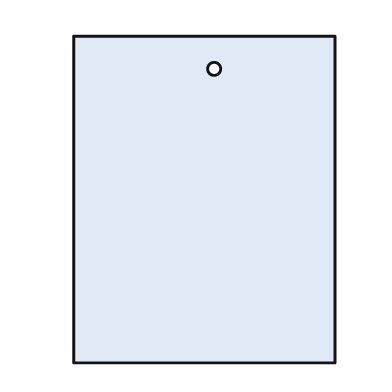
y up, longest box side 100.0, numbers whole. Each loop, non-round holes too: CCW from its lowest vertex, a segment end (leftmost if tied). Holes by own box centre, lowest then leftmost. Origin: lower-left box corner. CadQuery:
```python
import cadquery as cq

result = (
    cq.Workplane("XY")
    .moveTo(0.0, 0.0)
    .lineTo(80.0, 0.0)
    .lineTo(80.0, 100.0)
    .lineTo(0.0, 100.0)
    .close()
    .moveTo(43.0, 90.0)
    .circle(2.0)
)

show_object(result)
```